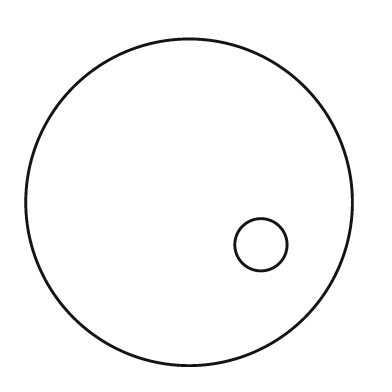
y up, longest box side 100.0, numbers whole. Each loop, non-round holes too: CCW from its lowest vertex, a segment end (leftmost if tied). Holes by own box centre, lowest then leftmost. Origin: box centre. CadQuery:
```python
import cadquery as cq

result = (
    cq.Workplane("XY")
    .moveTo(0.0, 0.0)
    .circle(50.0)
    .moveTo(22.0, -13.0)
    .circle(8.0)
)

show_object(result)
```